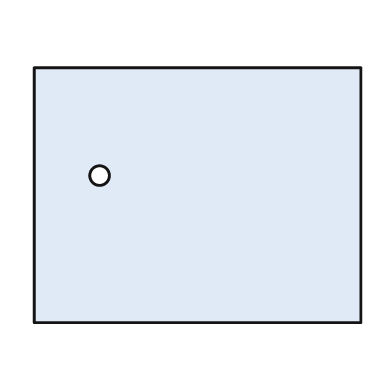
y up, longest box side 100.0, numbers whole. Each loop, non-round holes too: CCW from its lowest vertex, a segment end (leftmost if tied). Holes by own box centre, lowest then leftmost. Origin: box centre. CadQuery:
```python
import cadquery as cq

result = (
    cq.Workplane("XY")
    .moveTo(-50.0, -39.0)
    .lineTo(50.0, -39.0)
    .lineTo(50.0, 39.0)
    .lineTo(-50.0, 39.0)
    .close()
    .moveTo(-30.0, 6.0)
    .circle(3.0)
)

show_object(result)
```